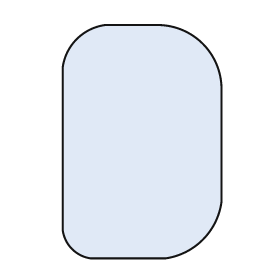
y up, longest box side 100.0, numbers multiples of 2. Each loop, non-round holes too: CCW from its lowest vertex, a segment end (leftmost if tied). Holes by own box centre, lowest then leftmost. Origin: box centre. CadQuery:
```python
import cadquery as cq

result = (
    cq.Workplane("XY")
    .moveTo(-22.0, -50.0)
    .lineTo(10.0, -50.0)
    .threePointArc((26.0, -42.0), (34.0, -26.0))
    .lineTo(34.0, 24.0)
    .threePointArc((26.0, 42.0), (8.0, 50.0))
    .lineTo(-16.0, 50.0)
    .threePointArc((-28.0, 44.0), (-34.0, 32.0))
    .lineTo(-34.0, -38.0)
    .threePointArc((-30.0, -46.0), (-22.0, -50.0))
    .close()
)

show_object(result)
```